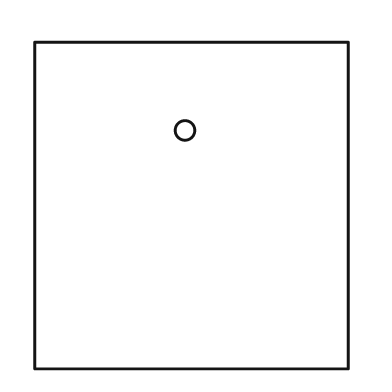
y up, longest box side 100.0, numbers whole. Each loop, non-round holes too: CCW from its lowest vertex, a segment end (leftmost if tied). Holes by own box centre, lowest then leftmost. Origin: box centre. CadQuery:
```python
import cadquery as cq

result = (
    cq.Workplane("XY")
    .moveTo(-48.0, -50.0)
    .lineTo(48.0, -50.0)
    .lineTo(48.0, 50.0)
    .lineTo(-48.0, 50.0)
    .close()
    .moveTo(-2.0, 23.0)
    .circle(3.0)
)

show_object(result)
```